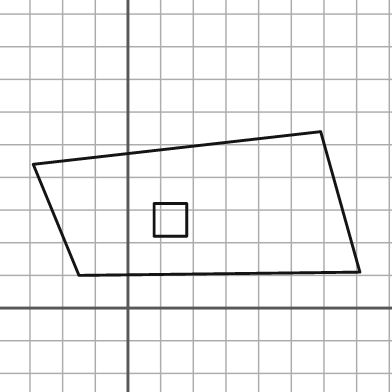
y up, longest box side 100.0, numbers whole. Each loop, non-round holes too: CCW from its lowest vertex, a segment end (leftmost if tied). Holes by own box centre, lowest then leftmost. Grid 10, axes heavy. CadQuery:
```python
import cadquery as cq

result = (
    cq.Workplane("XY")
    .moveTo(-15.0, 10.0)
    .lineTo(71.0, 11.0)
    .lineTo(59.0, 54.0)
    .lineTo(-29.0, 44.0)
    .close()
    .moveTo(8.0, 22.0)
    .lineTo(18.0, 22.0)
    .lineTo(18.0, 32.0)
    .lineTo(8.0, 32.0)
    .close()
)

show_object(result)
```